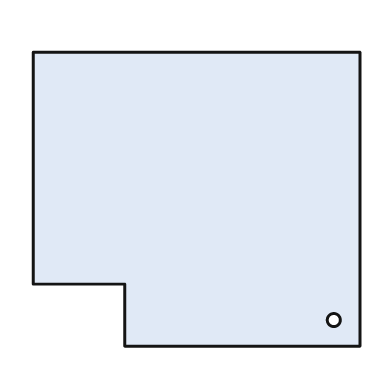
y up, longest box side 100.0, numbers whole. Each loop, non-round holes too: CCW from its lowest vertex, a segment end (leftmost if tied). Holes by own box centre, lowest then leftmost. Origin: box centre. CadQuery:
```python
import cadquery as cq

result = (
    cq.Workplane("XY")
    .moveTo(-22.0, -45.0)
    .lineTo(50.0, -45.0)
    .lineTo(50.0, 45.0)
    .lineTo(-50.0, 45.0)
    .lineTo(-50.0, -26.0)
    .lineTo(-22.0, -26.0)
    .close()
    .moveTo(42.0, -37.0)
    .circle(2.0)
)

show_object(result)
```